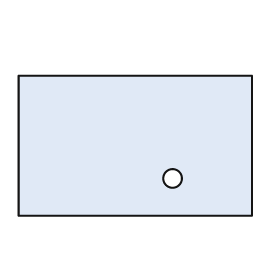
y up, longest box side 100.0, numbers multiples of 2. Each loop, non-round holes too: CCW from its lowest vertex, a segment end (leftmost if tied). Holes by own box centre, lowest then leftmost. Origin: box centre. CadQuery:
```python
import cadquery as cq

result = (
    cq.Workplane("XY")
    .moveTo(-50.0, -30.0)
    .lineTo(50.0, -30.0)
    .lineTo(50.0, 30.0)
    .lineTo(-50.0, 30.0)
    .close()
    .moveTo(16.0, -14.0)
    .circle(4.0)
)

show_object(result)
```